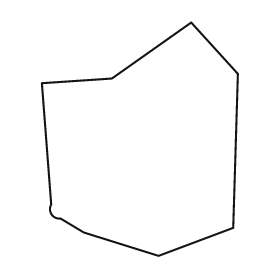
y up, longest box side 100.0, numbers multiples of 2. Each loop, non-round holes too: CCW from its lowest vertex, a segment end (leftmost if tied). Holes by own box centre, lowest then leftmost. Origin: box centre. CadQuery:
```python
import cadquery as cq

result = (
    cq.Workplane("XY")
    .moveTo(8.0, -50.0)
    .lineTo(40.0, -38.0)
    .lineTo(42.0, 28.0)
    .lineTo(22.0, 50.0)
    .lineTo(-12.0, 26.0)
    .lineTo(-42.0, 24.0)
    .lineTo(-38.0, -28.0)
    .threePointArc((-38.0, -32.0), (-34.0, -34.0))
    .lineTo(-24.0, -40.0)
    .close()
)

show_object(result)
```